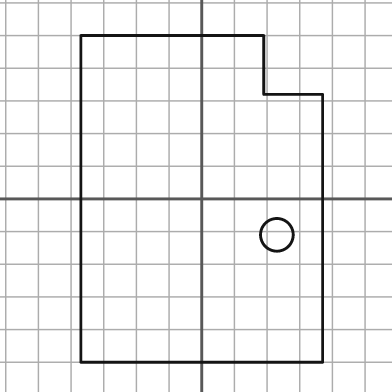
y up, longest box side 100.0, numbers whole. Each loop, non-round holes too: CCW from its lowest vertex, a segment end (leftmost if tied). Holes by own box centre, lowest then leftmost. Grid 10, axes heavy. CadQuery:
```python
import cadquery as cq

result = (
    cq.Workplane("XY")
    .moveTo(-37.0, -50.0)
    .lineTo(37.0, -50.0)
    .lineTo(37.0, 32.0)
    .lineTo(19.0, 32.0)
    .lineTo(19.0, 50.0)
    .lineTo(-37.0, 50.0)
    .close()
    .moveTo(23.0, -11.0)
    .circle(5.0)
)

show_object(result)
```